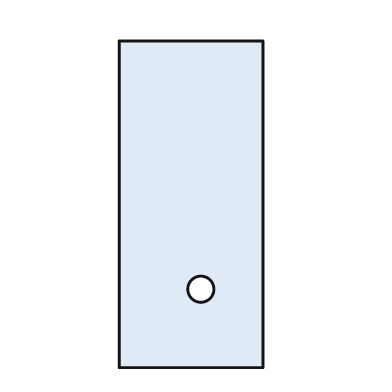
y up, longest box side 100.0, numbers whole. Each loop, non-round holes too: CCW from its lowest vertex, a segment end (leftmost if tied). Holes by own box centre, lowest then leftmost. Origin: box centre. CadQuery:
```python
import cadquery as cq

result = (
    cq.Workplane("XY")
    .moveTo(-22.0, -50.0)
    .lineTo(22.0, -50.0)
    .lineTo(22.0, 50.0)
    .lineTo(-22.0, 50.0)
    .close()
    .moveTo(3.0, -26.0)
    .circle(4.0)
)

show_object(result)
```